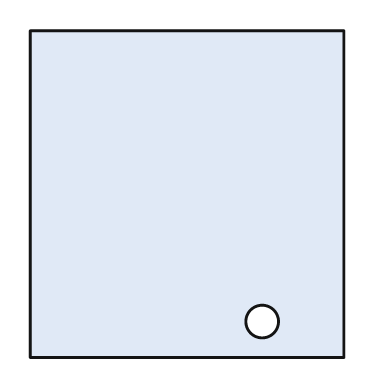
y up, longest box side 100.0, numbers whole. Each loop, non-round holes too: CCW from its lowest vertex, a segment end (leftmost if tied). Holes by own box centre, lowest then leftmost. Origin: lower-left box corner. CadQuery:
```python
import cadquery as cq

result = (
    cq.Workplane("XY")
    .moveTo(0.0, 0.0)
    .lineTo(96.0, 0.0)
    .lineTo(96.0, 100.0)
    .lineTo(0.0, 100.0)
    .close()
    .moveTo(71.0, 11.0)
    .circle(5.0)
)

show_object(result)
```